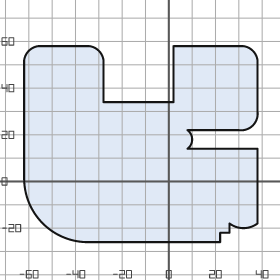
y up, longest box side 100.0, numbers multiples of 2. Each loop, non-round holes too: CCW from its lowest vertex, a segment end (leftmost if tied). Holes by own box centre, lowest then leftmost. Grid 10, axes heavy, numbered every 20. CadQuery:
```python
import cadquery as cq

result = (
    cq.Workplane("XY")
    .moveTo(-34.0, -26.0)
    .lineTo(22.0, -26.0)
    .lineTo(22.0, -22.0)
    .lineTo(26.0, -22.0)
    .lineTo(26.0, -18.0)
    .threePointArc((32.0, -20.0), (38.0, -18.0))
    .lineTo(38.0, 14.0)
    .lineTo(8.0, 14.0)
    .threePointArc((10.0, 18.0), (8.0, 22.0))
    .lineTo(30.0, 22.0)
    .threePointArc((36.0, 24.0), (38.0, 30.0))
    .lineTo(38.0, 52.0)
    .threePointArc((36.0, 56.0), (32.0, 58.0))
    .lineTo(2.0, 58.0)
    .lineTo(2.0, 34.0)
    .lineTo(-28.0, 34.0)
    .lineTo(-28.0, 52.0)
    .threePointArc((-30.0, 56.0), (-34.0, 58.0))
    .lineTo(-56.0, 58.0)
    .threePointArc((-60.0, 56.0), (-62.0, 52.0))
    .lineTo(-62.0, 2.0)
    .threePointArc((-54.0, -18.0), (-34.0, -26.0))
    .close()
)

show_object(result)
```